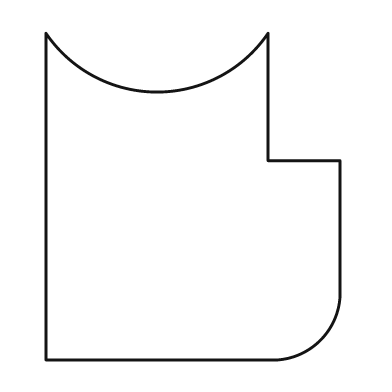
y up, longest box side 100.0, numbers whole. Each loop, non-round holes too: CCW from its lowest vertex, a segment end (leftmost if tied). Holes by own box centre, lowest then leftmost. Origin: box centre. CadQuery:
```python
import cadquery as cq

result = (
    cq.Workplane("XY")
    .moveTo(-45.0, -50.0)
    .lineTo(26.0, -50.0)
    .threePointArc((39.0, -44.0), (45.0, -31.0))
    .lineTo(45.0, 11.0)
    .lineTo(23.0, 11.0)
    .lineTo(23.0, 50.0)
    .threePointArc((-11.0, 32.0), (-45.0, 50.0))
    .close()
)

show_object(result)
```